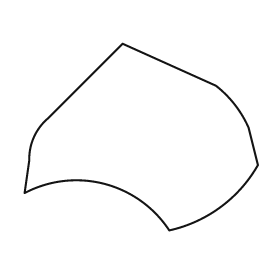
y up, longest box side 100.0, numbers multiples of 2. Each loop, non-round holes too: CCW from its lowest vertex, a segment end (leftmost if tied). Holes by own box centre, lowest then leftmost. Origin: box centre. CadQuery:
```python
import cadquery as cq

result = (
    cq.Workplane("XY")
    .moveTo(12.0, -40.0)
    .threePointArc((34.0, -30.0), (50.0, -12.0))
    .lineTo(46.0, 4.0)
    .threePointArc((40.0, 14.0), (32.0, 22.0))
    .lineTo(-8.0, 40.0)
    .lineTo(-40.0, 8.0)
    .threePointArc((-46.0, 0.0), (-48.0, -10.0))
    .lineTo(-50.0, -24.0)
    .threePointArc((-16.0, -20.0), (12.0, -40.0))
    .close()
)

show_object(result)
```